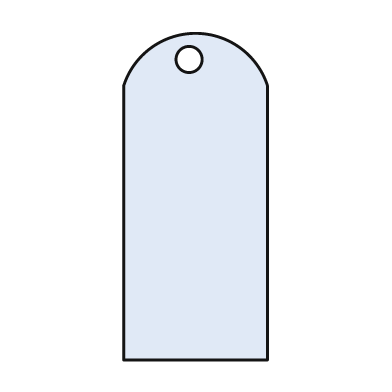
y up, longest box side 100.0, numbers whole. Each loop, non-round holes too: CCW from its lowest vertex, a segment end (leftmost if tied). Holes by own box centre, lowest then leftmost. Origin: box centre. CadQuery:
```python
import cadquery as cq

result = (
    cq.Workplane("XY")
    .moveTo(-22.0, -50.0)
    .lineTo(22.0, -50.0)
    .lineTo(22.0, 34.0)
    .threePointArc((0.0, 50.0), (-22.0, 34.0))
    .close()
    .moveTo(-2.0, 42.0)
    .circle(4.0)
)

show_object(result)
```